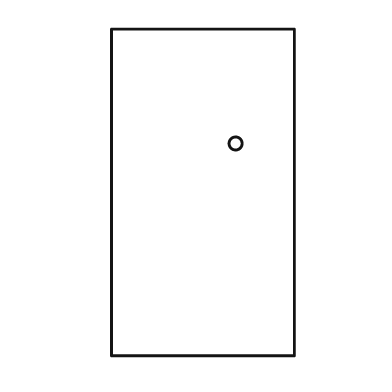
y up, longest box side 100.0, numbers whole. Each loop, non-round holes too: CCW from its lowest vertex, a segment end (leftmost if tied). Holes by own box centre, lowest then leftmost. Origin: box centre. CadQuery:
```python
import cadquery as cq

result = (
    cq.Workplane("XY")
    .moveTo(-28.0, -50.0)
    .lineTo(28.0, -50.0)
    .lineTo(28.0, 50.0)
    .lineTo(-28.0, 50.0)
    .close()
    .moveTo(10.0, 15.0)
    .circle(2.0)
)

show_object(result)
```